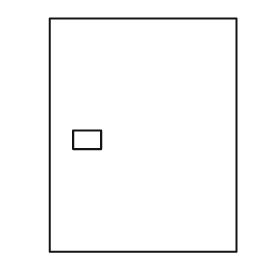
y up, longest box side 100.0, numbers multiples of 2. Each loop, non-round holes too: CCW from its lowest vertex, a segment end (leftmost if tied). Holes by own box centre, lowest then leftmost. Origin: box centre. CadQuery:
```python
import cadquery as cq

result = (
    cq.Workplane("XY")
    .moveTo(-40.0, -50.0)
    .lineTo(40.0, -50.0)
    .lineTo(40.0, 50.0)
    .lineTo(-40.0, 50.0)
    .close()
    .moveTo(-30.0, -6.0)
    .lineTo(-18.0, -6.0)
    .lineTo(-18.0, 2.0)
    .lineTo(-30.0, 2.0)
    .close()
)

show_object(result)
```